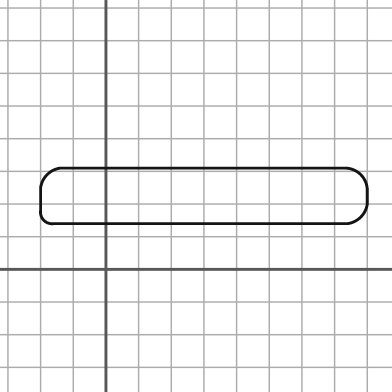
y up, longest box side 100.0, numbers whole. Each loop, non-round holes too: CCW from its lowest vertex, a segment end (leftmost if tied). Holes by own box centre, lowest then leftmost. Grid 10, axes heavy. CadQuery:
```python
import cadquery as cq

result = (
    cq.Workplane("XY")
    .moveTo(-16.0, 14.0)
    .lineTo(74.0, 14.0)
    .threePointArc((78.0, 16.0), (80.0, 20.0))
    .lineTo(80.0, 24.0)
    .threePointArc((78.0, 29.0), (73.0, 31.0))
    .lineTo(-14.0, 31.0)
    .threePointArc((-18.0, 29.0), (-20.0, 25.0))
    .lineTo(-20.0, 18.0)
    .threePointArc((-19.0, 15.0), (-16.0, 14.0))
    .close()
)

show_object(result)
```